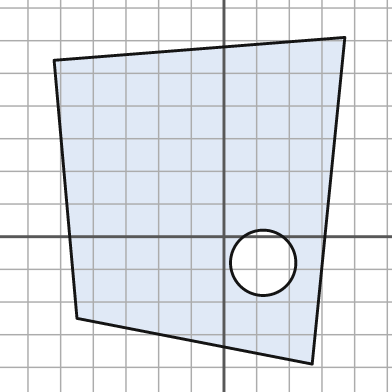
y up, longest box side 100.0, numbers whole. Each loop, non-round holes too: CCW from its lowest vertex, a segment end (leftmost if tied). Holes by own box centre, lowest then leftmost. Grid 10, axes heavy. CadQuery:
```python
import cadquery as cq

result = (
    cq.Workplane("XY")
    .moveTo(27.0, -39.0)
    .lineTo(37.0, 61.0)
    .lineTo(-52.0, 54.0)
    .lineTo(-45.0, -25.0)
    .close()
    .moveTo(12.0, -8.0)
    .circle(10.0)
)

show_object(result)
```